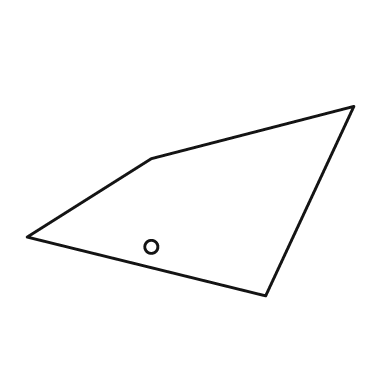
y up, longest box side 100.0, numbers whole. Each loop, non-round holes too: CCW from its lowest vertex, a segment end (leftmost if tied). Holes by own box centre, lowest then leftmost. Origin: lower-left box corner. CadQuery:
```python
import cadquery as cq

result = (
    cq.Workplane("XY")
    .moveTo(73.0, 0.0)
    .lineTo(100.0, 58.0)
    .lineTo(38.0, 42.0)
    .lineTo(0.0, 18.0)
    .close()
    .moveTo(38.0, 15.0)
    .circle(2.0)
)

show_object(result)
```